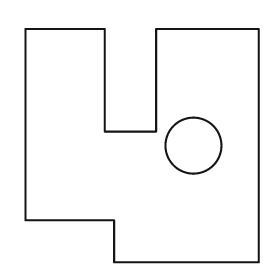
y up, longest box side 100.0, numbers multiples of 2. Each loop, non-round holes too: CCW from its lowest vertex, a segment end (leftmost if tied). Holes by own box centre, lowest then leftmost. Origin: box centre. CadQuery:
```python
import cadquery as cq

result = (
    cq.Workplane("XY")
    .moveTo(-12.0, -50.0)
    .lineTo(50.0, -50.0)
    .lineTo(50.0, 50.0)
    .lineTo(6.0, 50.0)
    .lineTo(6.0, 6.0)
    .lineTo(-16.0, 6.0)
    .lineTo(-16.0, 50.0)
    .lineTo(-50.0, 50.0)
    .lineTo(-50.0, -32.0)
    .lineTo(-12.0, -32.0)
    .close()
    .moveTo(22.0, 0.0)
    .circle(12.0)
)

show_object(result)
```